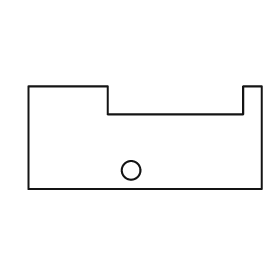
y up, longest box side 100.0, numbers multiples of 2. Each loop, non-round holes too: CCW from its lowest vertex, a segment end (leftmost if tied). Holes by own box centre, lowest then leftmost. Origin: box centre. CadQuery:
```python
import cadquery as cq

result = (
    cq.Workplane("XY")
    .moveTo(-50.0, -22.0)
    .lineTo(50.0, -22.0)
    .lineTo(50.0, 22.0)
    .lineTo(42.0, 22.0)
    .lineTo(42.0, 10.0)
    .lineTo(-16.0, 10.0)
    .lineTo(-16.0, 22.0)
    .lineTo(-50.0, 22.0)
    .close()
    .moveTo(-6.0, -14.0)
    .circle(4.0)
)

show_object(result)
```